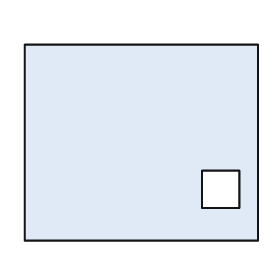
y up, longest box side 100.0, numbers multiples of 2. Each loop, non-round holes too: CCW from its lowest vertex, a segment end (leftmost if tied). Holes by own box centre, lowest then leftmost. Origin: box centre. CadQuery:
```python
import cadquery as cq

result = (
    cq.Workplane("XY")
    .moveTo(-50.0, -42.0)
    .lineTo(50.0, -42.0)
    .lineTo(50.0, 42.0)
    .lineTo(-50.0, 42.0)
    .close()
    .moveTo(26.0, -28.0)
    .lineTo(42.0, -28.0)
    .lineTo(42.0, -12.0)
    .lineTo(26.0, -12.0)
    .close()
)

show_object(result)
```